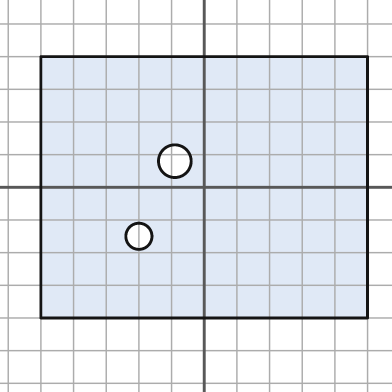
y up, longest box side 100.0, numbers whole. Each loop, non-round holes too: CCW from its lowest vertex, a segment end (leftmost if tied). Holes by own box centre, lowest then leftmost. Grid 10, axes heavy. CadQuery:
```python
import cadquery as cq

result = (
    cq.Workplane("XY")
    .moveTo(-50.0, -40.0)
    .lineTo(50.0, -40.0)
    .lineTo(50.0, 40.0)
    .lineTo(-50.0, 40.0)
    .close()
    .moveTo(-20.0, -15.0)
    .circle(4.0)
    .moveTo(-9.0, 8.0)
    .circle(5.0)
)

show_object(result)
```